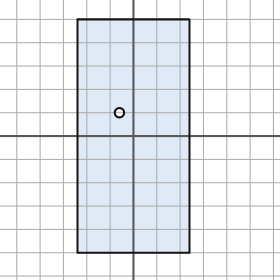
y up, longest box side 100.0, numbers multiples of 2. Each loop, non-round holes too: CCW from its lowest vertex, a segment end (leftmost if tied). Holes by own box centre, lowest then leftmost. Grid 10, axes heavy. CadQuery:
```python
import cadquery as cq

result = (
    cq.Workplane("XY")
    .moveTo(-24.0, -50.0)
    .lineTo(24.0, -50.0)
    .lineTo(24.0, 50.0)
    .lineTo(-24.0, 50.0)
    .close()
    .moveTo(-6.0, 10.0)
    .circle(2.0)
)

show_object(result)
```